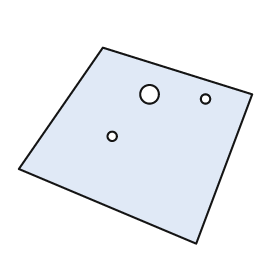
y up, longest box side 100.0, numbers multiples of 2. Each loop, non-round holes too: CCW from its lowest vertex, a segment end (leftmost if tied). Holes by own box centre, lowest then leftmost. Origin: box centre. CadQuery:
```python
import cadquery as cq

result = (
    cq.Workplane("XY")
    .moveTo(26.0, -42.0)
    .lineTo(50.0, 22.0)
    .lineTo(-14.0, 42.0)
    .lineTo(-50.0, -10.0)
    .close()
    .moveTo(-10.0, 4.0)
    .circle(2.0)
    .moveTo(30.0, 20.0)
    .circle(2.0)
    .moveTo(6.0, 22.0)
    .circle(4.0)
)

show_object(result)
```